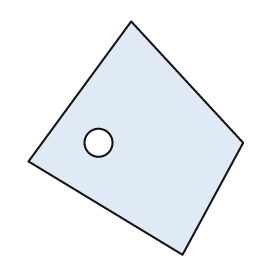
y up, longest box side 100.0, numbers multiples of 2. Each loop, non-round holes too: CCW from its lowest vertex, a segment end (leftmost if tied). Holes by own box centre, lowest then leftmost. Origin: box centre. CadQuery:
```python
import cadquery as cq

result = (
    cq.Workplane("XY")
    .moveTo(20.0, -50.0)
    .lineTo(46.0, -2.0)
    .lineTo(-2.0, 50.0)
    .lineTo(-46.0, -10.0)
    .close()
    .moveTo(-16.0, -2.0)
    .circle(6.0)
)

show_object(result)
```